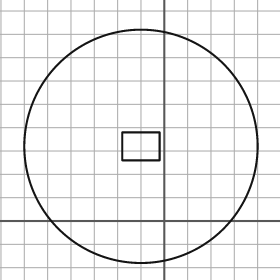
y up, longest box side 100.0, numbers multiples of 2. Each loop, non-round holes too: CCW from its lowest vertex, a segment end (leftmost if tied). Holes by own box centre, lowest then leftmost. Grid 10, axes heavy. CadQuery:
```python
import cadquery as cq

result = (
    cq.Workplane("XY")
    .moveTo(-10.0, 32.0)
    .circle(50.0)
    .moveTo(-18.0, 26.0)
    .lineTo(-2.0, 26.0)
    .lineTo(-2.0, 38.0)
    .lineTo(-18.0, 38.0)
    .close()
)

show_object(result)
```